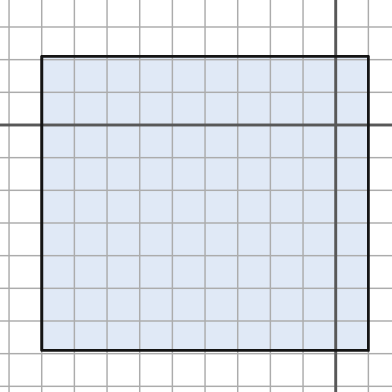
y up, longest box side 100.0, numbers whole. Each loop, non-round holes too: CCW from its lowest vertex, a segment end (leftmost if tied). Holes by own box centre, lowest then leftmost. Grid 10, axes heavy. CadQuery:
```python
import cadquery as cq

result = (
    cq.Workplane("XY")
    .moveTo(-90.0, -69.0)
    .lineTo(10.0, -69.0)
    .lineTo(10.0, 21.0)
    .lineTo(-90.0, 21.0)
    .close()
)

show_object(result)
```